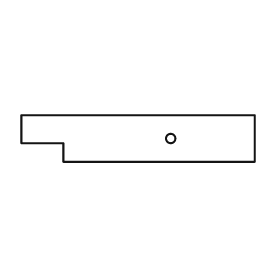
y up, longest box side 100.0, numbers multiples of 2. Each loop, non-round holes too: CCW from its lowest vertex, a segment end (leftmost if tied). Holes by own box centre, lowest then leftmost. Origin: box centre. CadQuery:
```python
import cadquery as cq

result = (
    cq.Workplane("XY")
    .moveTo(-32.0, -10.0)
    .lineTo(50.0, -10.0)
    .lineTo(50.0, 10.0)
    .lineTo(-50.0, 10.0)
    .lineTo(-50.0, -2.0)
    .lineTo(-32.0, -2.0)
    .close()
    .moveTo(14.0, 0.0)
    .circle(2.0)
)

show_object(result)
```